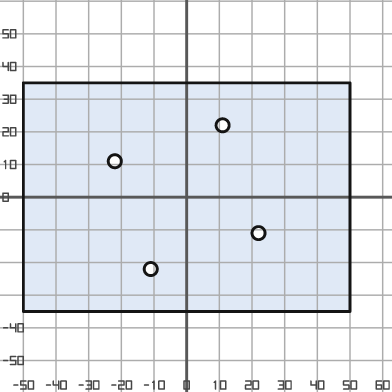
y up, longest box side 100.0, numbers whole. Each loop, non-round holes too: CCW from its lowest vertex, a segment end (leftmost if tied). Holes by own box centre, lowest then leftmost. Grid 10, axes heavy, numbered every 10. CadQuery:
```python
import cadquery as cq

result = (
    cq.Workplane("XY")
    .moveTo(-50.0, -35.0)
    .lineTo(50.0, -35.0)
    .lineTo(50.0, 35.0)
    .lineTo(-50.0, 35.0)
    .close()
    .moveTo(-11.0, -22.0)
    .circle(2.0)
    .moveTo(22.0, -11.0)
    .circle(2.0)
    .moveTo(-22.0, 11.0)
    .circle(2.0)
    .moveTo(11.0, 22.0)
    .circle(2.0)
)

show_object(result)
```